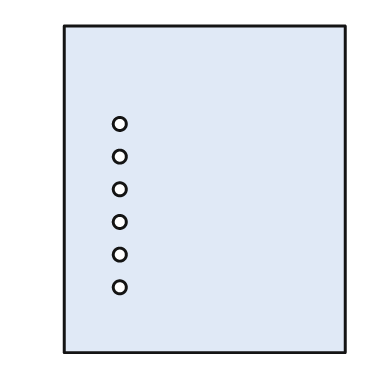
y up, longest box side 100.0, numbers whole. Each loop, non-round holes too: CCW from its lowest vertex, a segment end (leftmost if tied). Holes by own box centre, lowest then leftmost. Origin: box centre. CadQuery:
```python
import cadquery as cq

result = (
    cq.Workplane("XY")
    .moveTo(-43.0, -50.0)
    .lineTo(43.0, -50.0)
    .lineTo(43.0, 50.0)
    .lineTo(-43.0, 50.0)
    .close()
    .moveTo(-26.0, -30.0)
    .circle(2.0)
    .moveTo(-26.0, -20.0)
    .circle(2.0)
    .moveTo(-26.0, -10.0)
    .circle(2.0)
    .moveTo(-26.0, 0.0)
    .circle(2.0)
    .moveTo(-26.0, 10.0)
    .circle(2.0)
    .moveTo(-26.0, 20.0)
    .circle(2.0)
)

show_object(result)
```